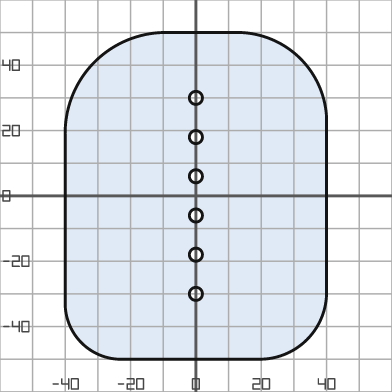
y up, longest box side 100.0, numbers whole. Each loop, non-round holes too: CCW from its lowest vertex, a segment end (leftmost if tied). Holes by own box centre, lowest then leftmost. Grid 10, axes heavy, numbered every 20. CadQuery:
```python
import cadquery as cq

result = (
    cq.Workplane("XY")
    .moveTo(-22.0, -50.0)
    .lineTo(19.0, -50.0)
    .threePointArc((34.0, -44.0), (40.0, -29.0))
    .lineTo(40.0, 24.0)
    .threePointArc((32.0, 42.0), (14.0, 50.0))
    .lineTo(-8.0, 50.0)
    .threePointArc((-31.0, 41.0), (-40.0, 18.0))
    .lineTo(-40.0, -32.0)
    .threePointArc((-35.0, -45.0), (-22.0, -50.0))
    .close()
    .moveTo(0.0, -30.0)
    .circle(2.0)
    .moveTo(0.0, -18.0)
    .circle(2.0)
    .moveTo(0.0, -6.0)
    .circle(2.0)
    .moveTo(0.0, 6.0)
    .circle(2.0)
    .moveTo(0.0, 18.0)
    .circle(2.0)
    .moveTo(0.0, 30.0)
    .circle(2.0)
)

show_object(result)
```